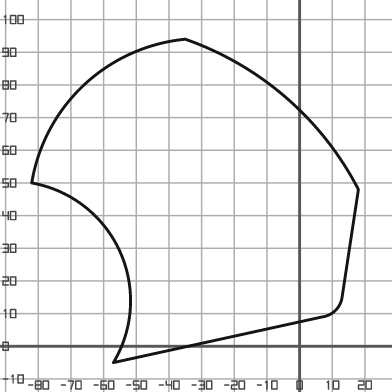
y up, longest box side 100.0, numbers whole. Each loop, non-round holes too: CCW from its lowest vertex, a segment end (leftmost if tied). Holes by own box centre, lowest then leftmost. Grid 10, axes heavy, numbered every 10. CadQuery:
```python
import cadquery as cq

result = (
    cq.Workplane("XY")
    .moveTo(-57.0, -5.0)
    .lineTo(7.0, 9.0)
    .threePointArc((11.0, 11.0), (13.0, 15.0))
    .lineTo(18.0, 48.0)
    .threePointArc((-4.0, 76.0), (-35.0, 94.0))
    .threePointArc((-66.0, 80.0), (-82.0, 50.0))
    .threePointArc((-55.0, 29.0), (-57.0, -5.0))
    .close()
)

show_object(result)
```